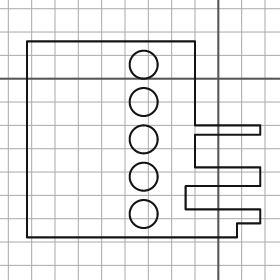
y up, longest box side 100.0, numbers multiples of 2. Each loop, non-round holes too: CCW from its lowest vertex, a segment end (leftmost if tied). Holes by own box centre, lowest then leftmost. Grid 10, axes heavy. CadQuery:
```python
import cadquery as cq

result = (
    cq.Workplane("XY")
    .moveTo(-82.0, -68.0)
    .lineTo(8.0, -68.0)
    .lineTo(8.0, -62.0)
    .lineTo(18.0, -62.0)
    .lineTo(18.0, -56.0)
    .lineTo(-14.0, -56.0)
    .lineTo(-14.0, -46.0)
    .lineTo(18.0, -46.0)
    .lineTo(18.0, -38.0)
    .lineTo(-10.0, -38.0)
    .lineTo(-10.0, -24.0)
    .lineTo(18.0, -24.0)
    .lineTo(18.0, -20.0)
    .lineTo(-10.0, -20.0)
    .lineTo(-10.0, 16.0)
    .lineTo(-82.0, 16.0)
    .close()
    .moveTo(-32.0, -58.0)
    .circle(6.0)
    .moveTo(-32.0, -42.0)
    .circle(6.0)
    .moveTo(-32.0, -26.0)
    .circle(6.0)
    .moveTo(-32.0, -10.0)
    .circle(6.0)
    .moveTo(-32.0, 6.0)
    .circle(6.0)
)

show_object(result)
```